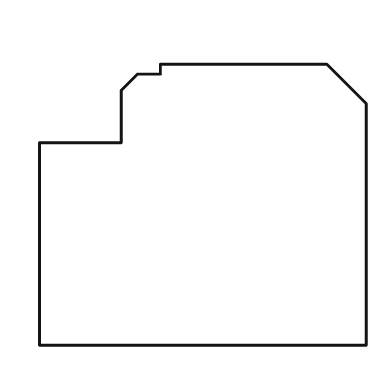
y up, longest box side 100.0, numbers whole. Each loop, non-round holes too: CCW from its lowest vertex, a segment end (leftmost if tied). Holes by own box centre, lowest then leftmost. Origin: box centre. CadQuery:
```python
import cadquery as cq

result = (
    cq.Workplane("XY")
    .moveTo(-50.0, -43.0)
    .lineTo(50.0, -43.0)
    .lineTo(50.0, 31.0)
    .lineTo(38.0, 43.0)
    .lineTo(-13.0, 43.0)
    .lineTo(-13.0, 40.0)
    .lineTo(-20.0, 40.0)
    .lineTo(-25.0, 35.0)
    .lineTo(-25.0, 19.0)
    .lineTo(-50.0, 19.0)
    .close()
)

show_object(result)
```